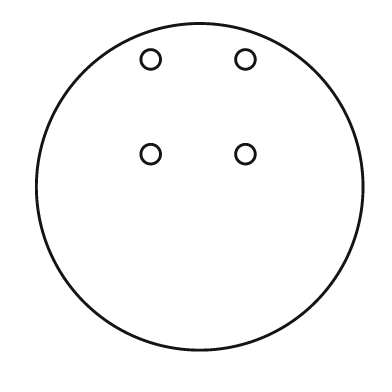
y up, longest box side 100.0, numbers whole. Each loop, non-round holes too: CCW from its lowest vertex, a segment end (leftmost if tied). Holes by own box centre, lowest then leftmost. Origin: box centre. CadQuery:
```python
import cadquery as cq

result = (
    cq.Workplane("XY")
    .moveTo(0.0, 0.0)
    .circle(50.0)
    .moveTo(-15.0, 10.0)
    .circle(3.0)
    .moveTo(14.0, 10.0)
    .circle(3.0)
    .moveTo(-15.0, 39.0)
    .circle(3.0)
    .moveTo(14.0, 39.0)
    .circle(3.0)
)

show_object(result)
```